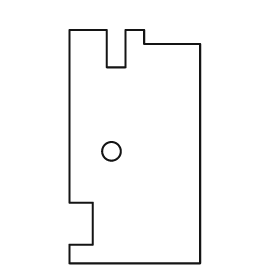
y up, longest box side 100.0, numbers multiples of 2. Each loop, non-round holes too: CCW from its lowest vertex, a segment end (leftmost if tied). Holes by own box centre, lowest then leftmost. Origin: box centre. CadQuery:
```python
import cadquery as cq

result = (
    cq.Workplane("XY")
    .moveTo(-28.0, -50.0)
    .lineTo(28.0, -50.0)
    .lineTo(28.0, 44.0)
    .lineTo(4.0, 44.0)
    .lineTo(4.0, 50.0)
    .lineTo(-4.0, 50.0)
    .lineTo(-4.0, 34.0)
    .lineTo(-12.0, 34.0)
    .lineTo(-12.0, 50.0)
    .lineTo(-28.0, 50.0)
    .lineTo(-28.0, -24.0)
    .lineTo(-18.0, -24.0)
    .lineTo(-18.0, -42.0)
    .lineTo(-28.0, -42.0)
    .close()
    .moveTo(-10.0, -2.0)
    .circle(4.0)
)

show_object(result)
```